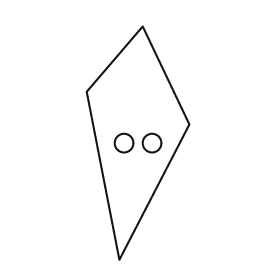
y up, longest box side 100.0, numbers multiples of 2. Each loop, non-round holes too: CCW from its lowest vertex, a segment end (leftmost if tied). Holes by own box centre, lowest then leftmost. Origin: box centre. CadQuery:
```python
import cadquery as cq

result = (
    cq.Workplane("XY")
    .moveTo(-8.0, -50.0)
    .lineTo(22.0, 8.0)
    .lineTo(2.0, 50.0)
    .lineTo(-22.0, 22.0)
    .close()
    .moveTo(-6.0, 0.0)
    .circle(4.0)
    .moveTo(6.0, 0.0)
    .circle(4.0)
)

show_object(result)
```